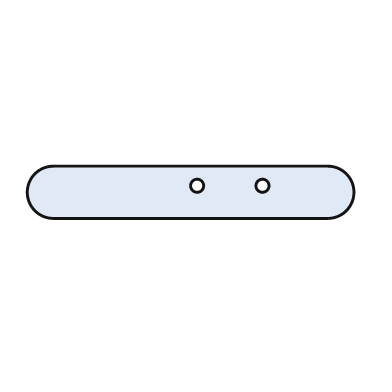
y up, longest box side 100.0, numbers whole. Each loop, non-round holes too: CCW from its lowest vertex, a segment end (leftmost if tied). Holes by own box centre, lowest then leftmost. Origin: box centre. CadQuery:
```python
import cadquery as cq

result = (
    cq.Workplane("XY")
    .moveTo(-42.0, -8.0)
    .lineTo(42.0, -8.0)
    .threePointArc((50.0, 0.0), (42.0, 8.0))
    .lineTo(-42.0, 8.0)
    .threePointArc((-50.0, 0.0), (-42.0, -8.0))
    .close()
    .moveTo(2.0, 2.0)
    .circle(2.0)
    .moveTo(22.0, 2.0)
    .circle(2.0)
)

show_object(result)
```